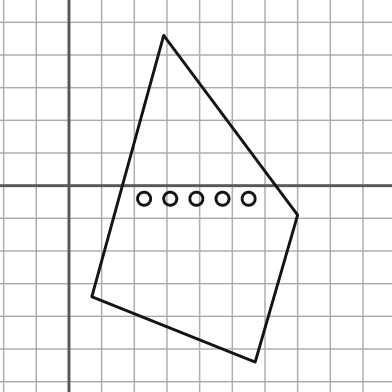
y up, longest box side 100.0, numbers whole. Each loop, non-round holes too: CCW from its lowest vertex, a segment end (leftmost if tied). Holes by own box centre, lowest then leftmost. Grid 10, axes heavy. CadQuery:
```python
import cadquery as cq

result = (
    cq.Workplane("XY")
    .moveTo(57.0, -54.0)
    .lineTo(70.0, -9.0)
    .lineTo(29.0, 46.0)
    .lineTo(7.0, -34.0)
    .close()
    .moveTo(23.0, -4.0)
    .circle(2.0)
    .moveTo(31.0, -4.0)
    .circle(2.0)
    .moveTo(39.0, -4.0)
    .circle(2.0)
    .moveTo(47.0, -4.0)
    .circle(2.0)
    .moveTo(55.0, -4.0)
    .circle(2.0)
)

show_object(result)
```